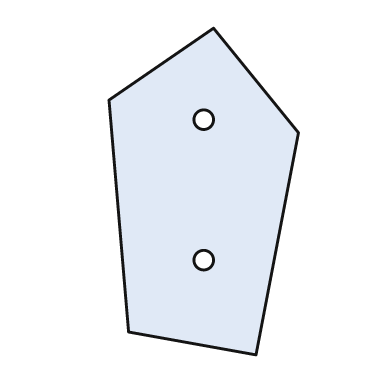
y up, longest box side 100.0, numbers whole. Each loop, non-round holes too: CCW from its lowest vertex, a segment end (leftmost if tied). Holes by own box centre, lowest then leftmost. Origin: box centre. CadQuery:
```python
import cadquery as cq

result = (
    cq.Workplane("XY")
    .moveTo(16.0, -50.0)
    .lineTo(29.0, 18.0)
    .lineTo(3.0, 50.0)
    .lineTo(-29.0, 28.0)
    .lineTo(-23.0, -43.0)
    .close()
    .moveTo(0.0, -21.0)
    .circle(3.0)
    .moveTo(0.0, 22.0)
    .circle(3.0)
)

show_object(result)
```